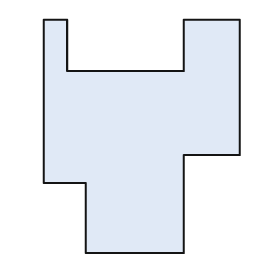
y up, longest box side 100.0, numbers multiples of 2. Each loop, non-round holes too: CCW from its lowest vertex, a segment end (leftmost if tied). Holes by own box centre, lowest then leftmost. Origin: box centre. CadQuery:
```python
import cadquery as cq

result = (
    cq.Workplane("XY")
    .moveTo(-24.0, -50.0)
    .lineTo(18.0, -50.0)
    .lineTo(18.0, -8.0)
    .lineTo(42.0, -8.0)
    .lineTo(42.0, 50.0)
    .lineTo(18.0, 50.0)
    .lineTo(18.0, 28.0)
    .lineTo(-32.0, 28.0)
    .lineTo(-32.0, 50.0)
    .lineTo(-42.0, 50.0)
    .lineTo(-42.0, -20.0)
    .lineTo(-24.0, -20.0)
    .close()
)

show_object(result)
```